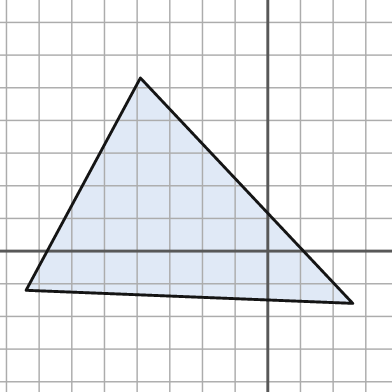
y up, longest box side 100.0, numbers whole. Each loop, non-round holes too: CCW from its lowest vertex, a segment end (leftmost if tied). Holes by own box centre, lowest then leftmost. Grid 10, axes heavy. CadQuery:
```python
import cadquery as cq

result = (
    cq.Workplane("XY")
    .moveTo(26.0, -16.0)
    .lineTo(-39.0, 53.0)
    .lineTo(-74.0, -12.0)
    .close()
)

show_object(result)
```